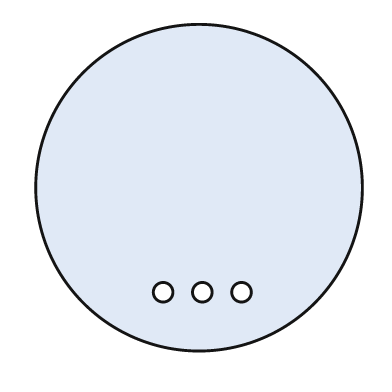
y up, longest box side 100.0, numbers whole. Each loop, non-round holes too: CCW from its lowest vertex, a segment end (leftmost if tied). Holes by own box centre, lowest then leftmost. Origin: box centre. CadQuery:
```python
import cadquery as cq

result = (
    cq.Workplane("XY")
    .moveTo(0.0, 0.0)
    .circle(50.0)
    .moveTo(-11.0, -32.0)
    .circle(3.0)
    .moveTo(1.0, -32.0)
    .circle(3.0)
    .moveTo(13.0, -32.0)
    .circle(3.0)
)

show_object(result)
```